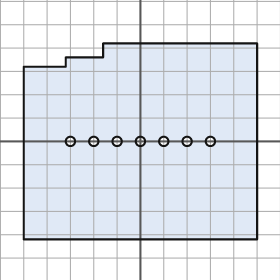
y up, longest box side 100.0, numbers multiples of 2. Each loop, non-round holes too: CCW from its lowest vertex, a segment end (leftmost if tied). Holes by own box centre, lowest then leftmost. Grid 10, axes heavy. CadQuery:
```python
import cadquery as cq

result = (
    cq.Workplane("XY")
    .moveTo(-50.0, -42.0)
    .lineTo(50.0, -42.0)
    .lineTo(50.0, 42.0)
    .lineTo(-16.0, 42.0)
    .lineTo(-16.0, 36.0)
    .lineTo(-32.0, 36.0)
    .lineTo(-32.0, 32.0)
    .lineTo(-50.0, 32.0)
    .close()
    .moveTo(-30.0, 0.0)
    .circle(2.0)
    .moveTo(-20.0, 0.0)
    .circle(2.0)
    .moveTo(-10.0, 0.0)
    .circle(2.0)
    .moveTo(0.0, 0.0)
    .circle(2.0)
    .moveTo(10.0, 0.0)
    .circle(2.0)
    .moveTo(20.0, 0.0)
    .circle(2.0)
    .moveTo(30.0, 0.0)
    .circle(2.0)
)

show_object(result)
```